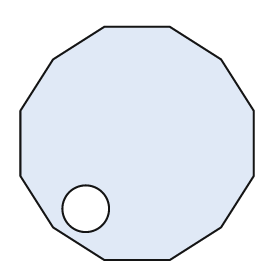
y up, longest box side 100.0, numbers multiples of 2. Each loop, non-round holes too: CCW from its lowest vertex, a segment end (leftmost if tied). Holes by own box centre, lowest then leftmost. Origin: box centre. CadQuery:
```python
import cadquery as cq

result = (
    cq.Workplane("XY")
    .moveTo(-14.0, -50.0)
    .lineTo(14.0, -50.0)
    .lineTo(36.0, -36.0)
    .lineTo(50.0, -14.0)
    .lineTo(50.0, 14.0)
    .lineTo(36.0, 36.0)
    .lineTo(14.0, 50.0)
    .lineTo(-14.0, 50.0)
    .lineTo(-36.0, 36.0)
    .lineTo(-50.0, 14.0)
    .lineTo(-50.0, -14.0)
    .lineTo(-36.0, -36.0)
    .close()
    .moveTo(-22.0, -28.0)
    .circle(10.0)
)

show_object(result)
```